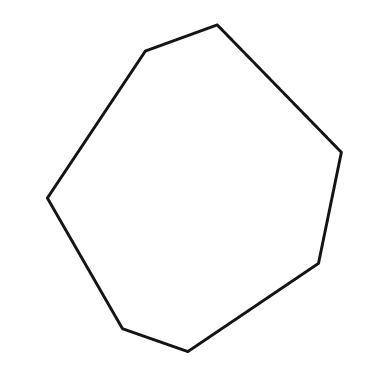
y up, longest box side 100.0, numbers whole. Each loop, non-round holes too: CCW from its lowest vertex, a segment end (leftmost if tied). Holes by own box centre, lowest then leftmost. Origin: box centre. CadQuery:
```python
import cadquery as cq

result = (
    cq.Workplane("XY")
    .moveTo(-2.0, -50.0)
    .lineTo(38.0, -23.0)
    .lineTo(45.0, 11.0)
    .lineTo(7.0, 50.0)
    .lineTo(-15.0, 42.0)
    .lineTo(-45.0, -3.0)
    .lineTo(-22.0, -43.0)
    .close()
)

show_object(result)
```